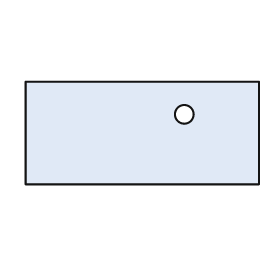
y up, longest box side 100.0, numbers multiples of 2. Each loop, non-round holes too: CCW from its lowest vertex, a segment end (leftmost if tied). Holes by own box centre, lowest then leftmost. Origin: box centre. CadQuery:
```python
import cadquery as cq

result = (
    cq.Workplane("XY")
    .moveTo(-50.0, -22.0)
    .lineTo(50.0, -22.0)
    .lineTo(50.0, 22.0)
    .lineTo(-50.0, 22.0)
    .close()
    .moveTo(18.0, 8.0)
    .circle(4.0)
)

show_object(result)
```